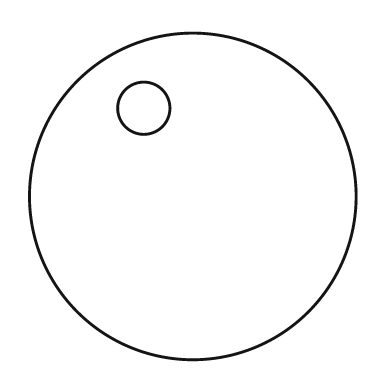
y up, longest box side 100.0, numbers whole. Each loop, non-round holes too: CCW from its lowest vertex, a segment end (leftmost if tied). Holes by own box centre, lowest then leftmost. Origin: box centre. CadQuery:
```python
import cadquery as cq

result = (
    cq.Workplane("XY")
    .moveTo(0.0, 0.0)
    .circle(50.0)
    .moveTo(-15.0, 27.0)
    .circle(8.0)
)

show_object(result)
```